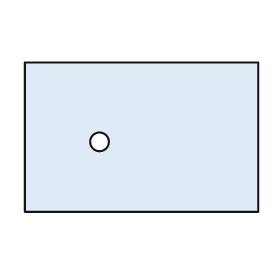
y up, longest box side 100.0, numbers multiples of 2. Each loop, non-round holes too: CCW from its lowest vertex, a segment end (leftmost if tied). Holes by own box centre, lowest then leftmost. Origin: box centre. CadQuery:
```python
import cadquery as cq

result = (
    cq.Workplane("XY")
    .moveTo(-50.0, -32.0)
    .lineTo(50.0, -32.0)
    .lineTo(50.0, 32.0)
    .lineTo(-50.0, 32.0)
    .close()
    .moveTo(-18.0, -2.0)
    .circle(4.0)
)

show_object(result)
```